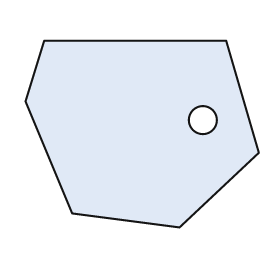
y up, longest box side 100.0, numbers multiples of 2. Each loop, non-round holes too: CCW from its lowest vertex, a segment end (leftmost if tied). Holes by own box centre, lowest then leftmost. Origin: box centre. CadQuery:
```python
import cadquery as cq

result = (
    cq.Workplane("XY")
    .moveTo(16.0, -40.0)
    .lineTo(50.0, -8.0)
    .lineTo(36.0, 40.0)
    .lineTo(-42.0, 40.0)
    .lineTo(-50.0, 14.0)
    .lineTo(-30.0, -34.0)
    .close()
    .moveTo(26.0, 6.0)
    .circle(6.0)
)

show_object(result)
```